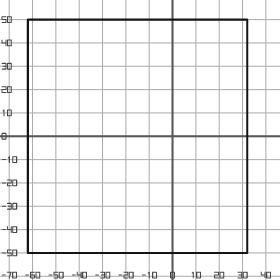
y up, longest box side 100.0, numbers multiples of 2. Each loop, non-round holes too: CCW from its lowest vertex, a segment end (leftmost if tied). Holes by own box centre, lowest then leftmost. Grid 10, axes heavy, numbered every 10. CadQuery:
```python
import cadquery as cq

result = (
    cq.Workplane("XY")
    .moveTo(-62.0, -50.0)
    .lineTo(32.0, -50.0)
    .lineTo(32.0, 50.0)
    .lineTo(-62.0, 50.0)
    .close()
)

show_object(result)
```